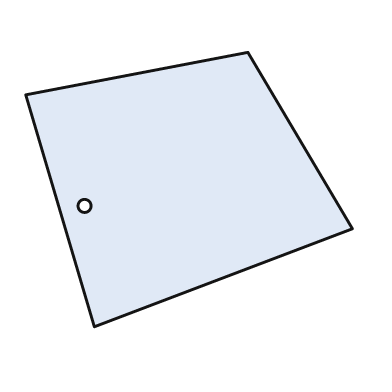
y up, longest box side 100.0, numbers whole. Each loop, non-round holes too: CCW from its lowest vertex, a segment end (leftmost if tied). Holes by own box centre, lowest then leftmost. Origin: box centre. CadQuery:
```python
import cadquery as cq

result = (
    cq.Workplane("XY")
    .moveTo(-29.0, -42.0)
    .lineTo(50.0, -12.0)
    .lineTo(18.0, 42.0)
    .lineTo(-50.0, 29.0)
    .close()
    .moveTo(-32.0, -5.0)
    .circle(2.0)
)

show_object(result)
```